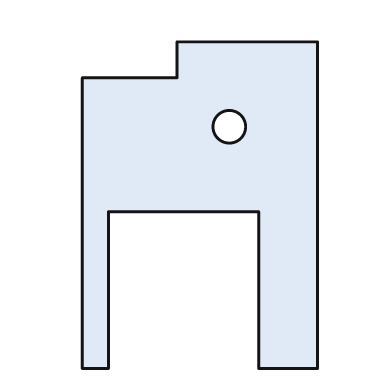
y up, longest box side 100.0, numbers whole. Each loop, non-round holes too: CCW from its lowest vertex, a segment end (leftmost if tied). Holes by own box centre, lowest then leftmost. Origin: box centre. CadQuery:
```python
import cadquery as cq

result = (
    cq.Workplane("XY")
    .moveTo(-36.0, -50.0)
    .lineTo(-28.0, -50.0)
    .lineTo(-28.0, -2.0)
    .lineTo(18.0, -2.0)
    .lineTo(18.0, -50.0)
    .lineTo(36.0, -50.0)
    .lineTo(36.0, 50.0)
    .lineTo(-7.0, 50.0)
    .lineTo(-7.0, 39.0)
    .lineTo(-36.0, 39.0)
    .close()
    .moveTo(9.0, 24.0)
    .circle(5.0)
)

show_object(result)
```